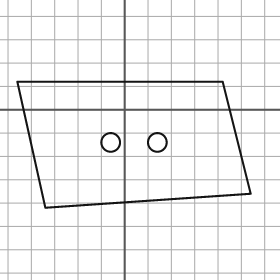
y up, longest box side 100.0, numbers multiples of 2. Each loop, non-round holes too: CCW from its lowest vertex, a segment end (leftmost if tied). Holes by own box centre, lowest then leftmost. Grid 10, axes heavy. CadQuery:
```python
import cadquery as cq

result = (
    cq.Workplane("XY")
    .moveTo(-34.0, -42.0)
    .lineTo(54.0, -36.0)
    .lineTo(42.0, 12.0)
    .lineTo(-46.0, 12.0)
    .close()
    .moveTo(-6.0, -14.0)
    .circle(4.0)
    .moveTo(14.0, -14.0)
    .circle(4.0)
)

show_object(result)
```